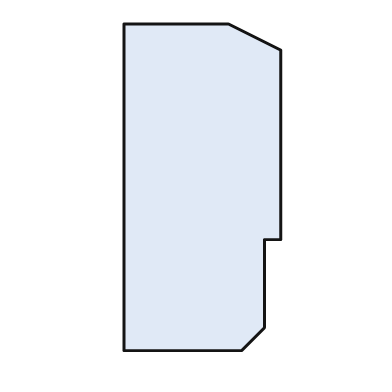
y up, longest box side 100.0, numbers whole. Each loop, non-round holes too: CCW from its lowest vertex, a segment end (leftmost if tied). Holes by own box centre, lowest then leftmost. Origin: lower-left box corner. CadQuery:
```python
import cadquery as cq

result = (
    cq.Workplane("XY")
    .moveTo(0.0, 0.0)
    .lineTo(36.0, 0.0)
    .lineTo(43.0, 7.0)
    .lineTo(43.0, 34.0)
    .lineTo(48.0, 34.0)
    .lineTo(48.0, 92.0)
    .lineTo(32.0, 100.0)
    .lineTo(0.0, 100.0)
    .close()
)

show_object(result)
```